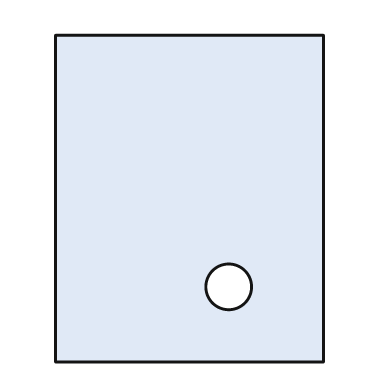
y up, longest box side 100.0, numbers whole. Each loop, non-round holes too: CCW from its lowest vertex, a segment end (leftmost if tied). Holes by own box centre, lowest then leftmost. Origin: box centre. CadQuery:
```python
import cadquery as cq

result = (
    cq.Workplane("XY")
    .moveTo(-41.0, -50.0)
    .lineTo(41.0, -50.0)
    .lineTo(41.0, 50.0)
    .lineTo(-41.0, 50.0)
    .close()
    .moveTo(12.0, -27.0)
    .circle(7.0)
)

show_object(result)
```